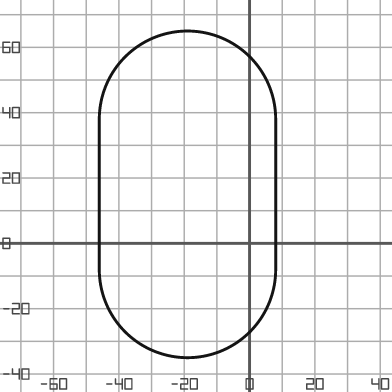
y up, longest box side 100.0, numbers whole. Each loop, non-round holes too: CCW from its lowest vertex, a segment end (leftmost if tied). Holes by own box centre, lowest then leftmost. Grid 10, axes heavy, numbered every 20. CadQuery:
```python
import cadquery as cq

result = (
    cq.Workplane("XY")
    .moveTo(-46.0, -8.0)
    .threePointArc((-19.0, -35.0), (8.0, -8.0))
    .lineTo(8.0, 38.0)
    .threePointArc((-19.0, 65.0), (-46.0, 38.0))
    .close()
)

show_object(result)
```